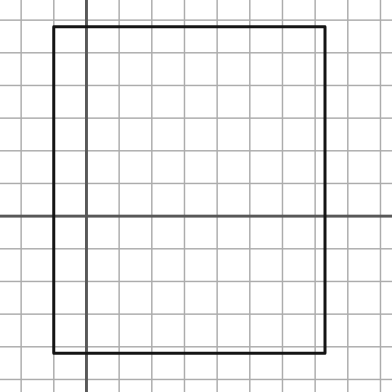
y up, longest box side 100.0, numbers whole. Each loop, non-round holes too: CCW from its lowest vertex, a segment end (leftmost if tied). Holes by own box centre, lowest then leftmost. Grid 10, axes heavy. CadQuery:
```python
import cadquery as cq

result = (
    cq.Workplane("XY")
    .moveTo(-10.0, -42.0)
    .lineTo(73.0, -42.0)
    .lineTo(73.0, 58.0)
    .lineTo(-10.0, 58.0)
    .close()
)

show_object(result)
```